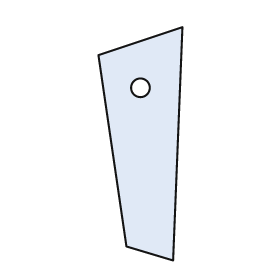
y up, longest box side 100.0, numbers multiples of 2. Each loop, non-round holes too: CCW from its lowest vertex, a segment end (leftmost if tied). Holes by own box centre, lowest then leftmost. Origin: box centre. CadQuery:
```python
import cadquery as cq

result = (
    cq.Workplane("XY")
    .moveTo(14.0, -50.0)
    .lineTo(18.0, 50.0)
    .lineTo(-18.0, 38.0)
    .lineTo(-6.0, -44.0)
    .close()
    .moveTo(0.0, 24.0)
    .circle(4.0)
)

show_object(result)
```